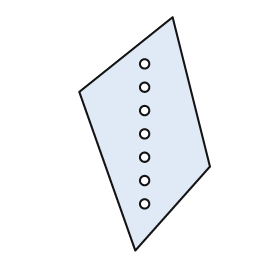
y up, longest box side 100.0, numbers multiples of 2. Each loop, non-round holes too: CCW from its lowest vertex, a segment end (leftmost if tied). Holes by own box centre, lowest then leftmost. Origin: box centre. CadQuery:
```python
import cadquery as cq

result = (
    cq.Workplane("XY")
    .moveTo(-4.0, -50.0)
    .lineTo(28.0, -14.0)
    .lineTo(12.0, 50.0)
    .lineTo(-28.0, 18.0)
    .close()
    .moveTo(0.0, -30.0)
    .circle(2.0)
    .moveTo(0.0, -20.0)
    .circle(2.0)
    .moveTo(0.0, -10.0)
    .circle(2.0)
    .moveTo(0.0, 0.0)
    .circle(2.0)
    .moveTo(0.0, 10.0)
    .circle(2.0)
    .moveTo(0.0, 20.0)
    .circle(2.0)
    .moveTo(0.0, 30.0)
    .circle(2.0)
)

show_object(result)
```